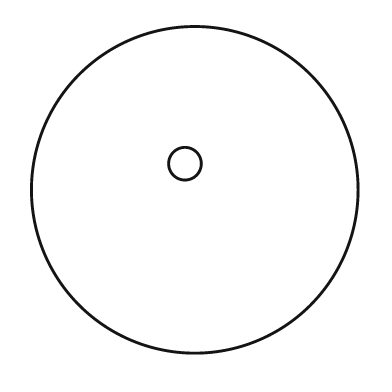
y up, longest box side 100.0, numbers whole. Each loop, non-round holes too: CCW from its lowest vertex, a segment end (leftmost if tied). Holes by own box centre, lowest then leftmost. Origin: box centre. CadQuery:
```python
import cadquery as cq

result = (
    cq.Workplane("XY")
    .moveTo(0.0, 0.0)
    .circle(50.0)
    .moveTo(-3.0, 8.0)
    .circle(5.0)
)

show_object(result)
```